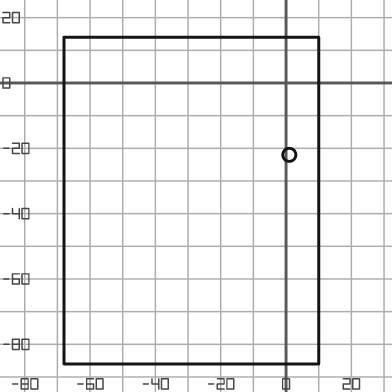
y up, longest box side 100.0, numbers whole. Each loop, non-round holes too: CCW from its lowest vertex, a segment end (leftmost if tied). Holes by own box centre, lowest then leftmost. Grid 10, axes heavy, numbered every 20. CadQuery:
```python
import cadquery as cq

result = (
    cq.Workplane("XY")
    .moveTo(-68.0, -86.0)
    .lineTo(10.0, -86.0)
    .lineTo(10.0, 14.0)
    .lineTo(-68.0, 14.0)
    .close()
    .moveTo(1.0, -22.0)
    .circle(2.0)
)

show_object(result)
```